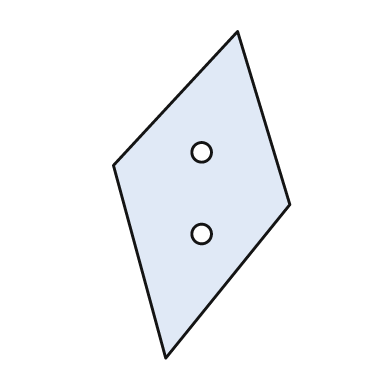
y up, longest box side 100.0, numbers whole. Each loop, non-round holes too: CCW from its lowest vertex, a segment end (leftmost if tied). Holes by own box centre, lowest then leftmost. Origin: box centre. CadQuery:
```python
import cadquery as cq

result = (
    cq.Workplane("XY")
    .moveTo(-11.0, -50.0)
    .lineTo(27.0, -3.0)
    .lineTo(11.0, 50.0)
    .lineTo(-27.0, 9.0)
    .close()
    .moveTo(0.0, -12.0)
    .circle(3.0)
    .moveTo(0.0, 13.0)
    .circle(3.0)
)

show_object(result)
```